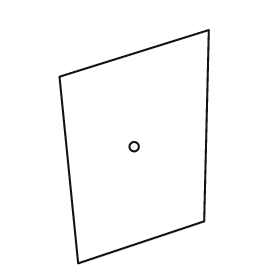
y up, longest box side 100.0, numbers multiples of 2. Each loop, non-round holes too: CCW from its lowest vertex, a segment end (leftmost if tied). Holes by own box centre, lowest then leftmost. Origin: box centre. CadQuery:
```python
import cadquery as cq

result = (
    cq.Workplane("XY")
    .moveTo(-24.0, -50.0)
    .lineTo(30.0, -32.0)
    .lineTo(32.0, 50.0)
    .lineTo(-32.0, 30.0)
    .close()
    .moveTo(0.0, 0.0)
    .circle(2.0)
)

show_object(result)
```